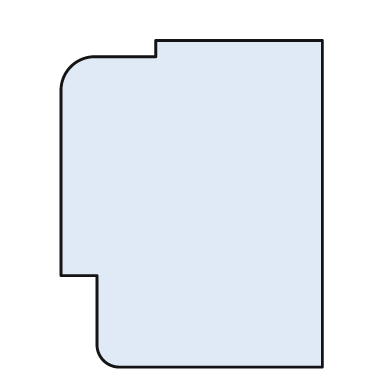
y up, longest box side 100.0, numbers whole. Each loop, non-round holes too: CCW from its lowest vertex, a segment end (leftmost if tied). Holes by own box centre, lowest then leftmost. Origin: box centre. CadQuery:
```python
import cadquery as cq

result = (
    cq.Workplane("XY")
    .moveTo(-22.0, -50.0)
    .lineTo(40.0, -50.0)
    .lineTo(40.0, 50.0)
    .lineTo(-11.0, 50.0)
    .lineTo(-11.0, 45.0)
    .lineTo(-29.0, 45.0)
    .threePointArc((-37.0, 42.0), (-40.0, 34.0))
    .lineTo(-40.0, -22.0)
    .lineTo(-29.0, -22.0)
    .lineTo(-29.0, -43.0)
    .threePointArc((-27.0, -48.0), (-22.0, -50.0))
    .close()
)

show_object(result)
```